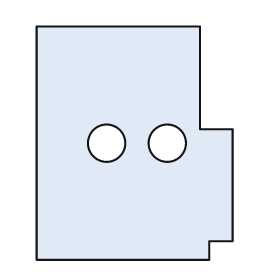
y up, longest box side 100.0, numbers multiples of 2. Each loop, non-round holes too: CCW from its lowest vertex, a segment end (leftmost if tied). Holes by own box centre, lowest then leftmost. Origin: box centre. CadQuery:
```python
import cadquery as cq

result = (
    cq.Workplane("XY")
    .moveTo(-42.0, -50.0)
    .lineTo(32.0, -50.0)
    .lineTo(32.0, -42.0)
    .lineTo(42.0, -42.0)
    .lineTo(42.0, 6.0)
    .lineTo(28.0, 6.0)
    .lineTo(28.0, 50.0)
    .lineTo(-42.0, 50.0)
    .close()
    .moveTo(-12.0, 0.0)
    .circle(8.0)
    .moveTo(14.0, 0.0)
    .circle(8.0)
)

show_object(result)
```